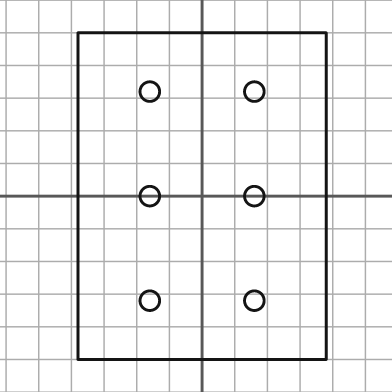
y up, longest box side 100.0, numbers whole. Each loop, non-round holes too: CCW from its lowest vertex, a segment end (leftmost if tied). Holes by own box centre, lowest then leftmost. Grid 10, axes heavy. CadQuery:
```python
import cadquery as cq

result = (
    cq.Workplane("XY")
    .moveTo(-38.0, -50.0)
    .lineTo(38.0, -50.0)
    .lineTo(38.0, 50.0)
    .lineTo(-38.0, 50.0)
    .close()
    .moveTo(-16.0, -32.0)
    .circle(3.0)
    .moveTo(16.0, -32.0)
    .circle(3.0)
    .moveTo(-16.0, 0.0)
    .circle(3.0)
    .moveTo(16.0, 0.0)
    .circle(3.0)
    .moveTo(-16.0, 32.0)
    .circle(3.0)
    .moveTo(16.0, 32.0)
    .circle(3.0)
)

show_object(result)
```